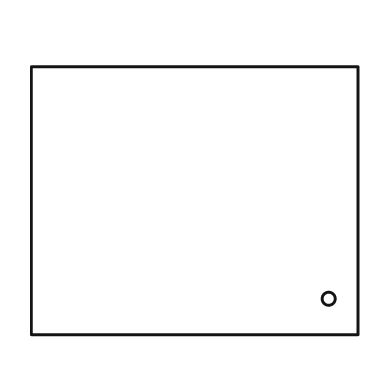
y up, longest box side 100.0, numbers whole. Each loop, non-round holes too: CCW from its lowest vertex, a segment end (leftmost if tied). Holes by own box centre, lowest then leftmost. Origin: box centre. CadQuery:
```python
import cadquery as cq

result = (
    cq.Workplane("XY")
    .moveTo(-50.0, -41.0)
    .lineTo(50.0, -41.0)
    .lineTo(50.0, 41.0)
    .lineTo(-50.0, 41.0)
    .close()
    .moveTo(41.0, -30.0)
    .circle(2.0)
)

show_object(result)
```